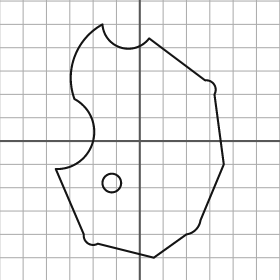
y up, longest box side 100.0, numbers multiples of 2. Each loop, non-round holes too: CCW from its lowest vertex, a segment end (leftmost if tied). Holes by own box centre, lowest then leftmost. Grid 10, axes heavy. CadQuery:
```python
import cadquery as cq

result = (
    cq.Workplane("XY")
    .moveTo(6.0, -50.0)
    .lineTo(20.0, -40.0)
    .threePointArc((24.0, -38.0), (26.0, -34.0))
    .lineTo(36.0, -10.0)
    .lineTo(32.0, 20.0)
    .threePointArc((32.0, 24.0), (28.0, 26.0))
    .lineTo(4.0, 44.0)
    .threePointArc((-8.0, 40.0), (-16.0, 50.0))
    .threePointArc((-28.0, 36.0), (-28.0, 18.0))
    .threePointArc((-20.0, 0.0), (-36.0, -12.0))
    .lineTo(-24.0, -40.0)
    .threePointArc((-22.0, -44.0), (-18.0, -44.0))
    .close()
    .moveTo(-12.0, -18.0)
    .circle(4.0)
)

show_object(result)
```